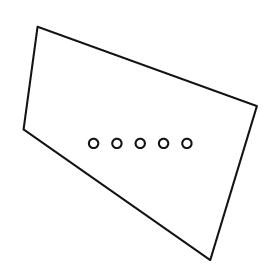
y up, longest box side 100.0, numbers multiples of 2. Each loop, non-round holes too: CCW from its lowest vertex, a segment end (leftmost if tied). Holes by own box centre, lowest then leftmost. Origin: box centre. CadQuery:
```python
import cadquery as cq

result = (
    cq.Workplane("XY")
    .moveTo(30.0, -50.0)
    .lineTo(50.0, 16.0)
    .lineTo(-44.0, 50.0)
    .lineTo(-50.0, 6.0)
    .close()
    .moveTo(-20.0, 0.0)
    .circle(2.0)
    .moveTo(-10.0, 0.0)
    .circle(2.0)
    .moveTo(0.0, 0.0)
    .circle(2.0)
    .moveTo(10.0, 0.0)
    .circle(2.0)
    .moveTo(20.0, 0.0)
    .circle(2.0)
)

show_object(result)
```